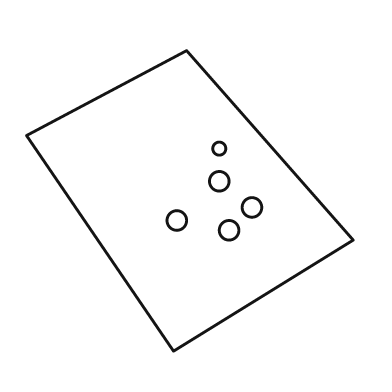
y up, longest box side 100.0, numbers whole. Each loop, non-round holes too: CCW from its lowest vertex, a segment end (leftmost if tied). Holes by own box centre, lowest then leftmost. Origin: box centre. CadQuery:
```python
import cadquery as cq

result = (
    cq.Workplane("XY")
    .moveTo(-5.0, -46.0)
    .lineTo(50.0, -12.0)
    .lineTo(-1.0, 46.0)
    .lineTo(-50.0, 20.0)
    .close()
    .moveTo(12.0, -9.0)
    .circle(3.0)
    .moveTo(-4.0, -6.0)
    .circle(3.0)
    .moveTo(19.0, -2.0)
    .circle(3.0)
    .moveTo(9.0, 6.0)
    .circle(3.0)
    .moveTo(9.0, 16.0)
    .circle(2.0)
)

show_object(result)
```